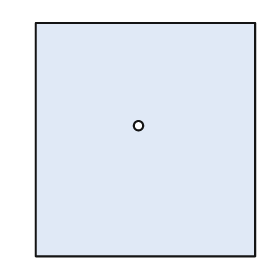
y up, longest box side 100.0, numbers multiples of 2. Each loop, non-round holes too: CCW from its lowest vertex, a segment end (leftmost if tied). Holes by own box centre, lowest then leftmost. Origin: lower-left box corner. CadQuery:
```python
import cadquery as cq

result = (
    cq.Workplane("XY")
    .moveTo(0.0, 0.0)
    .lineTo(94.0, 0.0)
    .lineTo(94.0, 100.0)
    .lineTo(0.0, 100.0)
    .close()
    .moveTo(44.0, 56.0)
    .circle(2.0)
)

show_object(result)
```